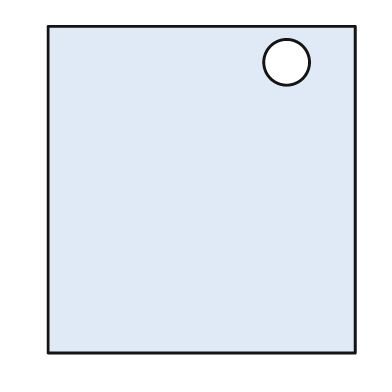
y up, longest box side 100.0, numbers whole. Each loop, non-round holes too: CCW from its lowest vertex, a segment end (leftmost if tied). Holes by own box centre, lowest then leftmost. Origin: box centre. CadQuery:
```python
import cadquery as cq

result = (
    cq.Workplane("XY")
    .moveTo(-47.0, -50.0)
    .lineTo(47.0, -50.0)
    .lineTo(47.0, 50.0)
    .lineTo(-47.0, 50.0)
    .close()
    .moveTo(26.0, 39.0)
    .circle(7.0)
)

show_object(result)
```